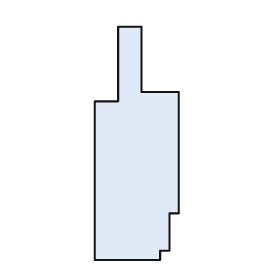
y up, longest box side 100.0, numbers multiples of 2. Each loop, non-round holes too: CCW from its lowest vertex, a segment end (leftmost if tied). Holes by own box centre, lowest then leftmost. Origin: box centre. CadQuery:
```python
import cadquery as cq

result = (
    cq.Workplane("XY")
    .moveTo(-18.0, -50.0)
    .lineTo(10.0, -50.0)
    .lineTo(10.0, -46.0)
    .lineTo(14.0, -46.0)
    .lineTo(14.0, -30.0)
    .lineTo(18.0, -30.0)
    .lineTo(18.0, 22.0)
    .lineTo(2.0, 22.0)
    .lineTo(2.0, 50.0)
    .lineTo(-8.0, 50.0)
    .lineTo(-8.0, 18.0)
    .lineTo(-18.0, 18.0)
    .close()
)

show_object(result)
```